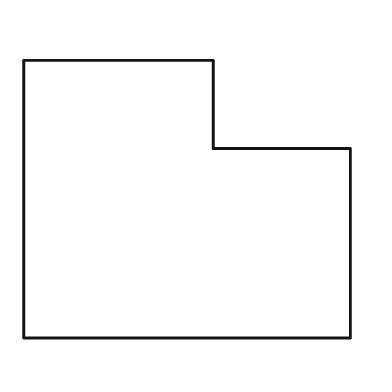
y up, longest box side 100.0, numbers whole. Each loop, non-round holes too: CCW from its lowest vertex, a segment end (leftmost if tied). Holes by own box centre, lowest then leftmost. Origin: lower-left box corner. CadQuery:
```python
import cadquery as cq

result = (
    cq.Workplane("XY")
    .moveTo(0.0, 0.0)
    .lineTo(100.0, 0.0)
    .lineTo(100.0, 58.0)
    .lineTo(58.0, 58.0)
    .lineTo(58.0, 85.0)
    .lineTo(0.0, 85.0)
    .close()
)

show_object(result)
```